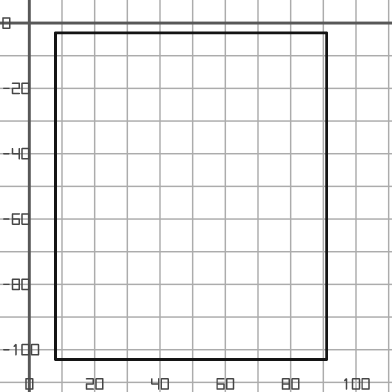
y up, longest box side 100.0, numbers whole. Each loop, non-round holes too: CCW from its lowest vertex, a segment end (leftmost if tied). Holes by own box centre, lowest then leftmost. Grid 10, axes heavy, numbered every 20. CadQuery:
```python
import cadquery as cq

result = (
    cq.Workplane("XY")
    .moveTo(8.0, -103.0)
    .lineTo(91.0, -103.0)
    .lineTo(91.0, -3.0)
    .lineTo(8.0, -3.0)
    .close()
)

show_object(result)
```